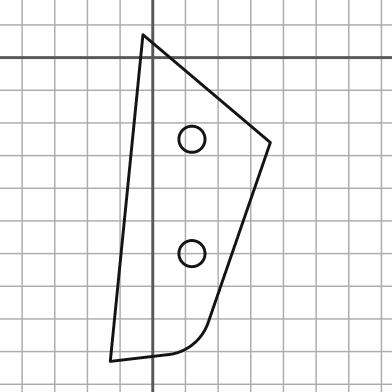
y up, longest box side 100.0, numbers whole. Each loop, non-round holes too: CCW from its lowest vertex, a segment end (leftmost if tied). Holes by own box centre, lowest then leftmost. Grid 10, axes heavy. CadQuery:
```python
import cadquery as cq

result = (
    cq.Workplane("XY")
    .moveTo(-13.0, -93.0)
    .lineTo(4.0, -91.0)
    .threePointArc((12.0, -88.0), (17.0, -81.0))
    .lineTo(36.0, -26.0)
    .lineTo(-3.0, 7.0)
    .close()
    .moveTo(12.0, -60.0)
    .circle(4.0)
    .moveTo(12.0, -25.0)
    .circle(4.0)
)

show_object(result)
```